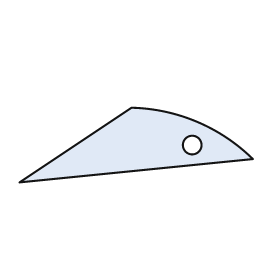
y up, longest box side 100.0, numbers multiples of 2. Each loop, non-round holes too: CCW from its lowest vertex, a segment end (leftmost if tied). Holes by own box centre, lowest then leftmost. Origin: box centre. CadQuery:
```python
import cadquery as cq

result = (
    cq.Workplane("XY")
    .moveTo(-50.0, -16.0)
    .lineTo(50.0, -6.0)
    .threePointArc((26.0, 10.0), (-2.0, 16.0))
    .close()
    .moveTo(24.0, 0.0)
    .circle(4.0)
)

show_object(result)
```